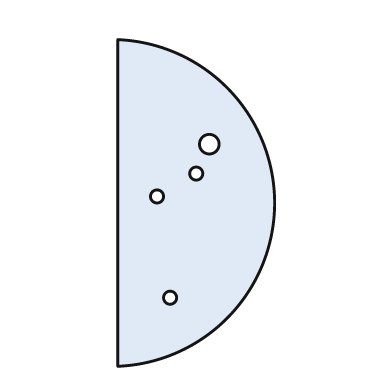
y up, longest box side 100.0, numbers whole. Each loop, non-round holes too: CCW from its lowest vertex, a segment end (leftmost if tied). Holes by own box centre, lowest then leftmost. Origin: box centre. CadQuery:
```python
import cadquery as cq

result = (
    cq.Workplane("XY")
    .moveTo(-24.0, -50.0)
    .threePointArc((24.0, 0.0), (-24.0, 50.0))
    .close()
    .moveTo(-8.0, -29.0)
    .circle(2.0)
    .moveTo(-12.0, 2.0)
    .circle(2.0)
    .moveTo(0.0, 9.0)
    .circle(2.0)
    .moveTo(4.0, 18.0)
    .circle(3.0)
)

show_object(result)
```